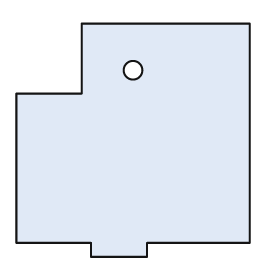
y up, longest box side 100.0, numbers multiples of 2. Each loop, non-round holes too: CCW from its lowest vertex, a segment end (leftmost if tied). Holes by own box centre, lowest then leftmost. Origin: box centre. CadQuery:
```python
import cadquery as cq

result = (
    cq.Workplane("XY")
    .moveTo(-18.0, -50.0)
    .lineTo(6.0, -50.0)
    .lineTo(6.0, -44.0)
    .lineTo(50.0, -44.0)
    .lineTo(50.0, 50.0)
    .lineTo(-22.0, 50.0)
    .lineTo(-22.0, 20.0)
    .lineTo(-50.0, 20.0)
    .lineTo(-50.0, -44.0)
    .lineTo(-18.0, -44.0)
    .close()
    .moveTo(0.0, 30.0)
    .circle(4.0)
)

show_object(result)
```